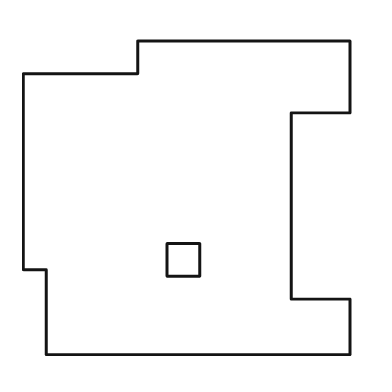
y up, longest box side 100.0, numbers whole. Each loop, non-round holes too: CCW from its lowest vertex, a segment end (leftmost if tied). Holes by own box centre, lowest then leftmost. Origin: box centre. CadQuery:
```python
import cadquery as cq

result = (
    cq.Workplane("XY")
    .moveTo(-43.0, -48.0)
    .lineTo(50.0, -48.0)
    .lineTo(50.0, -31.0)
    .lineTo(32.0, -31.0)
    .lineTo(32.0, 26.0)
    .lineTo(50.0, 26.0)
    .lineTo(50.0, 48.0)
    .lineTo(-15.0, 48.0)
    .lineTo(-15.0, 38.0)
    .lineTo(-50.0, 38.0)
    .lineTo(-50.0, -22.0)
    .lineTo(-43.0, -22.0)
    .close()
    .moveTo(-6.0, -24.0)
    .lineTo(4.0, -24.0)
    .lineTo(4.0, -14.0)
    .lineTo(-6.0, -14.0)
    .close()
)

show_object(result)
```